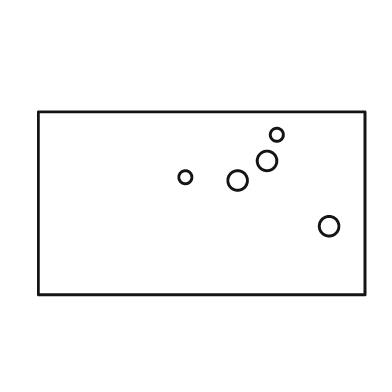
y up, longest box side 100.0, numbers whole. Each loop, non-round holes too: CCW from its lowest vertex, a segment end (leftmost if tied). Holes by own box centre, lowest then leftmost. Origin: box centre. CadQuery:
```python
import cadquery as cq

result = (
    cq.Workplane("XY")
    .moveTo(-50.0, -28.0)
    .lineTo(50.0, -28.0)
    .lineTo(50.0, 28.0)
    .lineTo(-50.0, 28.0)
    .close()
    .moveTo(39.0, -7.0)
    .circle(3.0)
    .moveTo(11.0, 7.0)
    .circle(3.0)
    .moveTo(-5.0, 8.0)
    .circle(2.0)
    .moveTo(20.0, 13.0)
    .circle(3.0)
    .moveTo(23.0, 21.0)
    .circle(2.0)
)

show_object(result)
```